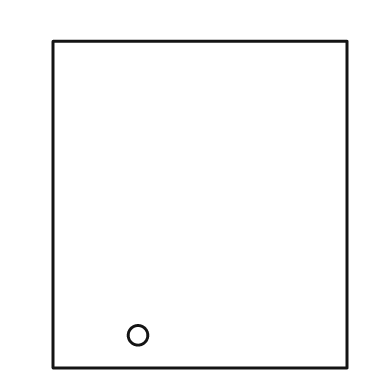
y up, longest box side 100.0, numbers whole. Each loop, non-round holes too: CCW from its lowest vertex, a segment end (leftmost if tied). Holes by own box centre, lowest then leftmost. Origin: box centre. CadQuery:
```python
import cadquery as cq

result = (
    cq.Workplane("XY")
    .moveTo(-45.0, -50.0)
    .lineTo(45.0, -50.0)
    .lineTo(45.0, 50.0)
    .lineTo(-45.0, 50.0)
    .close()
    .moveTo(-19.0, -40.0)
    .circle(3.0)
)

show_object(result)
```